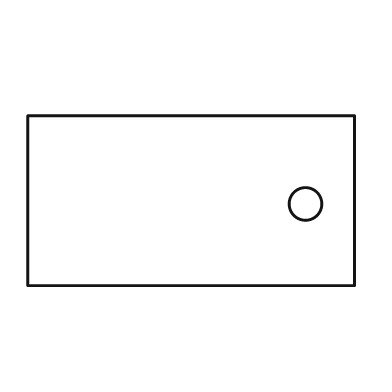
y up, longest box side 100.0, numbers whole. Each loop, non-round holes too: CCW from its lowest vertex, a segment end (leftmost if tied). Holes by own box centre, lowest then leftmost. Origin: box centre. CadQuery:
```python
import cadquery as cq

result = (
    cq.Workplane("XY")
    .moveTo(-50.0, -26.0)
    .lineTo(50.0, -26.0)
    .lineTo(50.0, 26.0)
    .lineTo(-50.0, 26.0)
    .close()
    .moveTo(35.0, -1.0)
    .circle(5.0)
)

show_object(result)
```